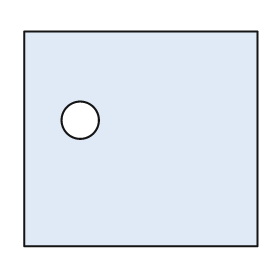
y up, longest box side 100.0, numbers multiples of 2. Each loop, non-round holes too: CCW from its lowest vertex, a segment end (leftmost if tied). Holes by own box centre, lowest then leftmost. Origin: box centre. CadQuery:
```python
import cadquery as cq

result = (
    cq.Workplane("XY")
    .moveTo(-50.0, -46.0)
    .lineTo(50.0, -46.0)
    .lineTo(50.0, 46.0)
    .lineTo(-50.0, 46.0)
    .close()
    .moveTo(-26.0, 8.0)
    .circle(8.0)
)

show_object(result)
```